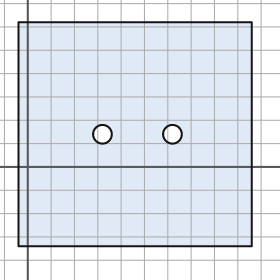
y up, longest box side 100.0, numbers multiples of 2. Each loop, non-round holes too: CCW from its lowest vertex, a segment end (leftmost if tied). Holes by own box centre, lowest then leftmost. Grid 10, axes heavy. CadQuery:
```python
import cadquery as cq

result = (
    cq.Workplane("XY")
    .moveTo(-4.0, -34.0)
    .lineTo(96.0, -34.0)
    .lineTo(96.0, 62.0)
    .lineTo(-4.0, 62.0)
    .close()
    .moveTo(32.0, 14.0)
    .circle(4.0)
    .moveTo(62.0, 14.0)
    .circle(4.0)
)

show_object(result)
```